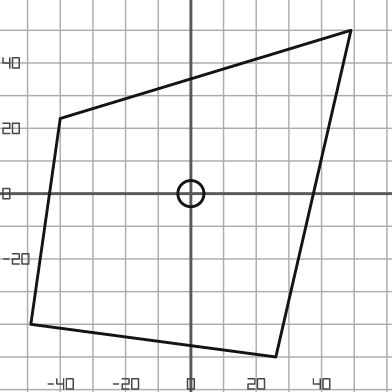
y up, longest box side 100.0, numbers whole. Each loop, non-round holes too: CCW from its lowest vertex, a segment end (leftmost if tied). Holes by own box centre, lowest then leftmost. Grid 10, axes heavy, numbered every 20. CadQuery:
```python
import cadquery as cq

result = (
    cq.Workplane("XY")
    .moveTo(26.0, -50.0)
    .lineTo(49.0, 50.0)
    .lineTo(-40.0, 23.0)
    .lineTo(-49.0, -40.0)
    .close()
    .moveTo(0.0, 0.0)
    .circle(4.0)
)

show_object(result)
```